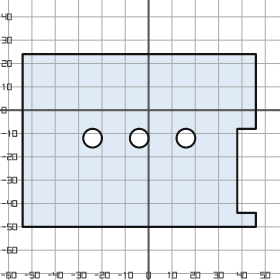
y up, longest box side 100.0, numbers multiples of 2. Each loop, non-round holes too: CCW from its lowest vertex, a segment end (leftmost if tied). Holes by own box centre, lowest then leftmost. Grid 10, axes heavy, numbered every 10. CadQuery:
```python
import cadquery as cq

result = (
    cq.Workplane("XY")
    .moveTo(-54.0, -50.0)
    .lineTo(46.0, -50.0)
    .lineTo(46.0, -44.0)
    .lineTo(38.0, -44.0)
    .lineTo(38.0, -8.0)
    .lineTo(46.0, -8.0)
    .lineTo(46.0, 24.0)
    .lineTo(-54.0, 24.0)
    .close()
    .moveTo(-24.0, -12.0)
    .circle(4.0)
    .moveTo(-4.0, -12.0)
    .circle(4.0)
    .moveTo(16.0, -12.0)
    .circle(4.0)
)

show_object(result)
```